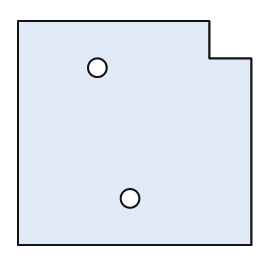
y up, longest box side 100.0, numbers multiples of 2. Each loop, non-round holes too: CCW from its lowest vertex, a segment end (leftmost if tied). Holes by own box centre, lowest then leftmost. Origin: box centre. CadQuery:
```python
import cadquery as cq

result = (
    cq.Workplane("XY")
    .moveTo(-50.0, -48.0)
    .lineTo(50.0, -48.0)
    .lineTo(50.0, 32.0)
    .lineTo(32.0, 32.0)
    .lineTo(32.0, 48.0)
    .lineTo(-50.0, 48.0)
    .close()
    .moveTo(-2.0, -28.0)
    .circle(4.0)
    .moveTo(-16.0, 28.0)
    .circle(4.0)
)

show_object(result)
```